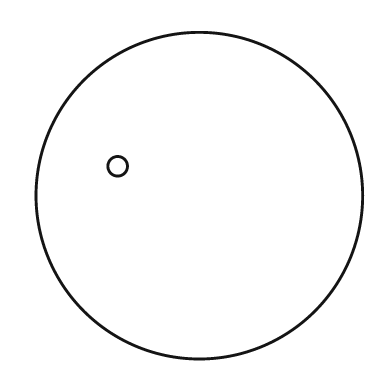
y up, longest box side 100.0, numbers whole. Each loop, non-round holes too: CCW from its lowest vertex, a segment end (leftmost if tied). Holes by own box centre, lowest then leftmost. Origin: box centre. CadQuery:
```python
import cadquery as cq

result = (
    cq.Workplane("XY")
    .moveTo(0.0, 0.0)
    .circle(50.0)
    .moveTo(-25.0, 9.0)
    .circle(3.0)
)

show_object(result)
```